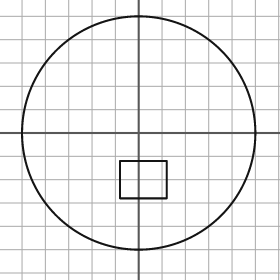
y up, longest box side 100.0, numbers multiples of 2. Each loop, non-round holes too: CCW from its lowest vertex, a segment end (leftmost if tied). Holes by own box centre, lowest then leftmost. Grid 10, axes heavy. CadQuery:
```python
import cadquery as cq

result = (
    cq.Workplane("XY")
    .moveTo(0.0, 0.0)
    .circle(50.0)
    .moveTo(-8.0, -28.0)
    .lineTo(12.0, -28.0)
    .lineTo(12.0, -12.0)
    .lineTo(-8.0, -12.0)
    .close()
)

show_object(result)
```